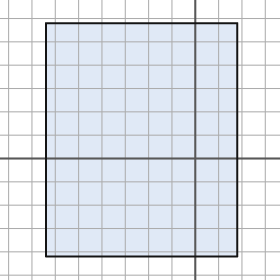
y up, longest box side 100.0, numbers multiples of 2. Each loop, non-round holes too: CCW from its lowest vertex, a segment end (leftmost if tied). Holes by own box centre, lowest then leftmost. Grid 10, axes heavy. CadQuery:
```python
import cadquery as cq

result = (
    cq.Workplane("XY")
    .moveTo(-64.0, -42.0)
    .lineTo(18.0, -42.0)
    .lineTo(18.0, 58.0)
    .lineTo(-64.0, 58.0)
    .close()
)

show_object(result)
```